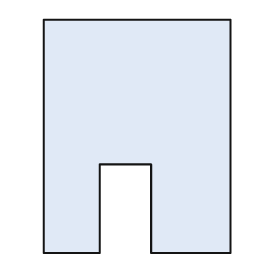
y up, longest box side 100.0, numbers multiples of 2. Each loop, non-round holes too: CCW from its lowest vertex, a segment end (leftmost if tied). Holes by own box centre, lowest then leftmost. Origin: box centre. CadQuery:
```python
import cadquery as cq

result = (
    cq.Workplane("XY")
    .moveTo(-40.0, -50.0)
    .lineTo(-16.0, -50.0)
    .lineTo(-16.0, -12.0)
    .lineTo(6.0, -12.0)
    .lineTo(6.0, -50.0)
    .lineTo(40.0, -50.0)
    .lineTo(40.0, 50.0)
    .lineTo(-40.0, 50.0)
    .close()
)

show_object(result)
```